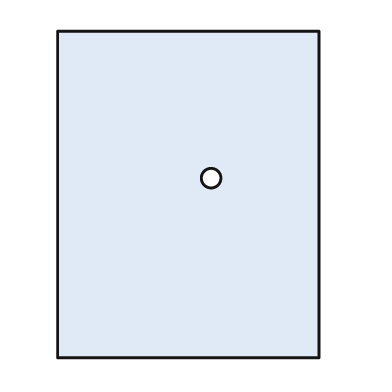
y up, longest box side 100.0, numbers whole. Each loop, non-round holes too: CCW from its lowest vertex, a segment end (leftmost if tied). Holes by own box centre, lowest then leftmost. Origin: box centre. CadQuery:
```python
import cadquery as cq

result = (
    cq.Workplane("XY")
    .moveTo(-40.0, -50.0)
    .lineTo(40.0, -50.0)
    .lineTo(40.0, 50.0)
    .lineTo(-40.0, 50.0)
    .close()
    .moveTo(7.0, 5.0)
    .circle(3.0)
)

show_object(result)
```